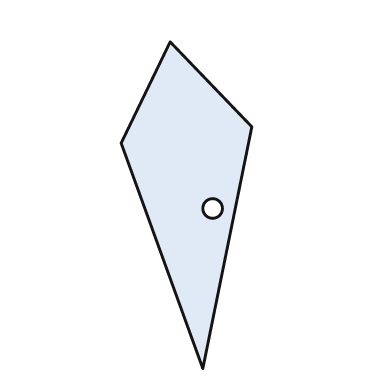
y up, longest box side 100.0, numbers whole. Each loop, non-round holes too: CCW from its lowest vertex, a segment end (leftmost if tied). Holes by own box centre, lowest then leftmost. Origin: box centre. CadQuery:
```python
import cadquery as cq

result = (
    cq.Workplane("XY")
    .moveTo(5.0, -50.0)
    .lineTo(20.0, 24.0)
    .lineTo(-5.0, 50.0)
    .lineTo(-20.0, 19.0)
    .close()
    .moveTo(8.0, -1.0)
    .circle(3.0)
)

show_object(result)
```